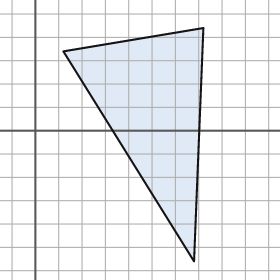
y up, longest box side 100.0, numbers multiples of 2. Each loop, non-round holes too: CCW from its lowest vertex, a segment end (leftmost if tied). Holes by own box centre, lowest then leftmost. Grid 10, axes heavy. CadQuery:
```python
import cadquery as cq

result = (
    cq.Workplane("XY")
    .moveTo(68.0, -56.0)
    .lineTo(72.0, 44.0)
    .lineTo(12.0, 34.0)
    .close()
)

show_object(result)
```